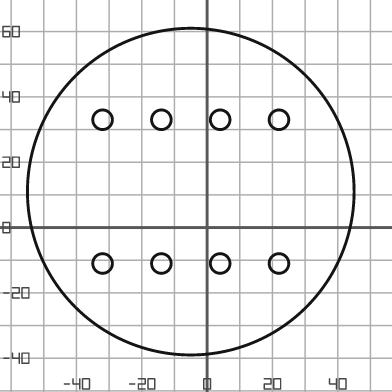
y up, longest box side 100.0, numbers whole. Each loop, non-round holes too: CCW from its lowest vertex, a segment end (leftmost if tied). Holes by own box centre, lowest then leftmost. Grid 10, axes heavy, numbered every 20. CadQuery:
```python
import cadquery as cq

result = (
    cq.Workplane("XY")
    .moveTo(-5.0, 11.0)
    .circle(50.0)
    .moveTo(-32.0, -11.0)
    .circle(3.0)
    .moveTo(-14.0, -11.0)
    .circle(3.0)
    .moveTo(4.0, -11.0)
    .circle(3.0)
    .moveTo(22.0, -11.0)
    .circle(3.0)
    .moveTo(-32.0, 33.0)
    .circle(3.0)
    .moveTo(-14.0, 33.0)
    .circle(3.0)
    .moveTo(4.0, 33.0)
    .circle(3.0)
    .moveTo(22.0, 33.0)
    .circle(3.0)
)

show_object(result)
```